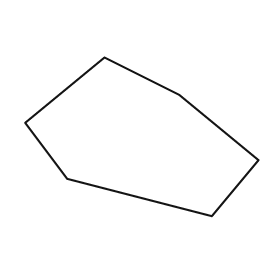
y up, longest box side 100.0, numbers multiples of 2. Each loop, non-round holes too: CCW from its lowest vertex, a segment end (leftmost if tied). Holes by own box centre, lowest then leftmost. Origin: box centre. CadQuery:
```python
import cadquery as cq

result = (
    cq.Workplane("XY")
    .moveTo(30.0, -34.0)
    .lineTo(50.0, -10.0)
    .lineTo(16.0, 18.0)
    .lineTo(-16.0, 34.0)
    .lineTo(-50.0, 6.0)
    .lineTo(-32.0, -18.0)
    .close()
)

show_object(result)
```